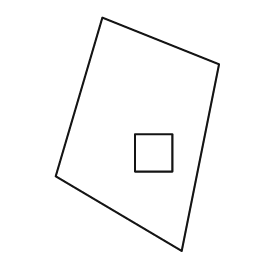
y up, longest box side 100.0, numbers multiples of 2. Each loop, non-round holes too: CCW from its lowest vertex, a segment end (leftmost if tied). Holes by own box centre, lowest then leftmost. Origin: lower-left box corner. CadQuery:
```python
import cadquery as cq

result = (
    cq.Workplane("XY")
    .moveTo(54.0, 0.0)
    .lineTo(70.0, 80.0)
    .lineTo(20.0, 100.0)
    .lineTo(0.0, 32.0)
    .close()
    .moveTo(34.0, 34.0)
    .lineTo(50.0, 34.0)
    .lineTo(50.0, 50.0)
    .lineTo(34.0, 50.0)
    .close()
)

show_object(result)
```